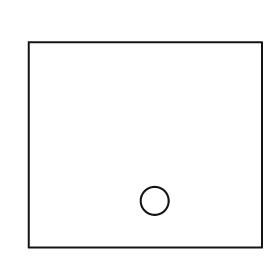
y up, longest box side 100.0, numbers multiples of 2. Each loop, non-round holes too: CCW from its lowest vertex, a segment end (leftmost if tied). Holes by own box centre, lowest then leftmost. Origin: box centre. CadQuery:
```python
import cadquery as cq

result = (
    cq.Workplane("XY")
    .moveTo(-50.0, -44.0)
    .lineTo(50.0, -44.0)
    .lineTo(50.0, 44.0)
    .lineTo(-50.0, 44.0)
    .close()
    .moveTo(4.0, -24.0)
    .circle(6.0)
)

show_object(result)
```